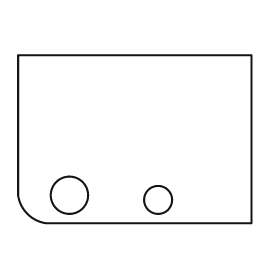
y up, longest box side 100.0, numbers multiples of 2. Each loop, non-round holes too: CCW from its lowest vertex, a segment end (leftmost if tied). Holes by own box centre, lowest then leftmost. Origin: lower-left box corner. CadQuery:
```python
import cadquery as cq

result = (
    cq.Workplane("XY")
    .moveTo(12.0, 0.0)
    .lineTo(100.0, 0.0)
    .lineTo(100.0, 72.0)
    .lineTo(0.0, 72.0)
    .lineTo(0.0, 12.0)
    .threePointArc((4.0, 4.0), (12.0, 0.0))
    .close()
    .moveTo(60.0, 10.0)
    .circle(6.0)
    .moveTo(22.0, 12.0)
    .circle(8.0)
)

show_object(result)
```